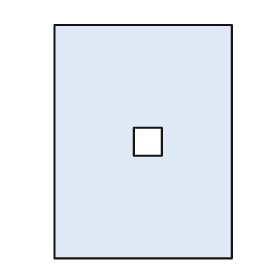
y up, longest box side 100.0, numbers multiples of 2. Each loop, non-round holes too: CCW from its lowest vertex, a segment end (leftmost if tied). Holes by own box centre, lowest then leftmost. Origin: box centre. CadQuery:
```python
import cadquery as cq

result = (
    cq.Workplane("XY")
    .moveTo(-38.0, -50.0)
    .lineTo(38.0, -50.0)
    .lineTo(38.0, 50.0)
    .lineTo(-38.0, 50.0)
    .close()
    .moveTo(-4.0, -6.0)
    .lineTo(8.0, -6.0)
    .lineTo(8.0, 6.0)
    .lineTo(-4.0, 6.0)
    .close()
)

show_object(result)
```